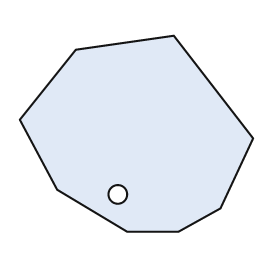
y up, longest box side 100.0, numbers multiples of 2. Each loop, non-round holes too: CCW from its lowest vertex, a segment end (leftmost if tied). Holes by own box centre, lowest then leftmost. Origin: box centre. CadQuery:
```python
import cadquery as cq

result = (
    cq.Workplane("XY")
    .moveTo(-4.0, -42.0)
    .lineTo(18.0, -42.0)
    .lineTo(36.0, -32.0)
    .lineTo(50.0, -2.0)
    .lineTo(16.0, 42.0)
    .lineTo(-26.0, 36.0)
    .lineTo(-50.0, 6.0)
    .lineTo(-34.0, -24.0)
    .close()
    .moveTo(-8.0, -26.0)
    .circle(4.0)
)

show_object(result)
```